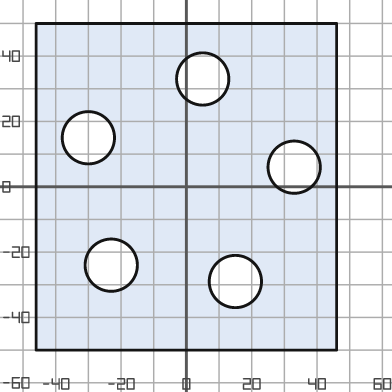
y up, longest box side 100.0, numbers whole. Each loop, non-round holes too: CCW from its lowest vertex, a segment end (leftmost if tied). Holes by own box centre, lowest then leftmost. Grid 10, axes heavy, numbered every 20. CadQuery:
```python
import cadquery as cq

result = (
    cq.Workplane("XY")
    .moveTo(-46.0, -50.0)
    .lineTo(46.0, -50.0)
    .lineTo(46.0, 50.0)
    .lineTo(-46.0, 50.0)
    .close()
    .moveTo(15.0, -29.0)
    .circle(8.0)
    .moveTo(-23.0, -24.0)
    .circle(8.0)
    .moveTo(33.0, 6.0)
    .circle(8.0)
    .moveTo(-30.0, 15.0)
    .circle(8.0)
    .moveTo(5.0, 33.0)
    .circle(8.0)
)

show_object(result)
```